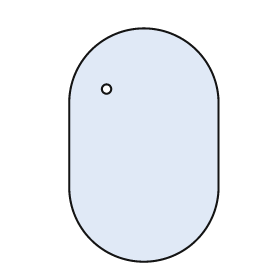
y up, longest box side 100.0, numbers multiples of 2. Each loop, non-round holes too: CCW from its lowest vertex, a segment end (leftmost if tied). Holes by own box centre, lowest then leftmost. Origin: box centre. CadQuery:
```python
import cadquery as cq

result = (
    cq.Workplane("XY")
    .moveTo(-32.0, -18.0)
    .threePointArc((0.0, -50.0), (32.0, -18.0))
    .lineTo(32.0, 18.0)
    .threePointArc((0.0, 50.0), (-32.0, 18.0))
    .close()
    .moveTo(-16.0, 24.0)
    .circle(2.0)
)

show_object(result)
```